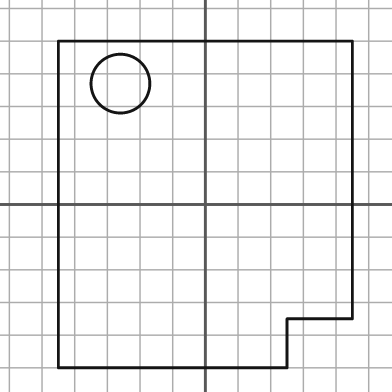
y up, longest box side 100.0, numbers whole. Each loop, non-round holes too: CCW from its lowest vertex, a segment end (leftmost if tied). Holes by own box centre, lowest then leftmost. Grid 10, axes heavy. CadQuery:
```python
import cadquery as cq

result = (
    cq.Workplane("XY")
    .moveTo(-45.0, -50.0)
    .lineTo(25.0, -50.0)
    .lineTo(25.0, -35.0)
    .lineTo(45.0, -35.0)
    .lineTo(45.0, 50.0)
    .lineTo(-45.0, 50.0)
    .close()
    .moveTo(-26.0, 37.0)
    .circle(9.0)
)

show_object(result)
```